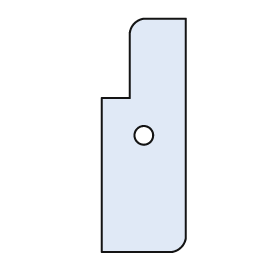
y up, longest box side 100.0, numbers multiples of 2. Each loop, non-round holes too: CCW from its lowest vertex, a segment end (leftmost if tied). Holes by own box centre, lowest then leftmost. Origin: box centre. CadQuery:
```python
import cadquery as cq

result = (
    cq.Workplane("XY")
    .moveTo(-18.0, -50.0)
    .lineTo(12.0, -50.0)
    .threePointArc((16.0, -48.0), (18.0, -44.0))
    .lineTo(18.0, 50.0)
    .lineTo(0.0, 50.0)
    .threePointArc((-4.0, 48.0), (-6.0, 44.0))
    .lineTo(-6.0, 16.0)
    .lineTo(-18.0, 16.0)
    .close()
    .moveTo(0.0, 0.0)
    .circle(4.0)
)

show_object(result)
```